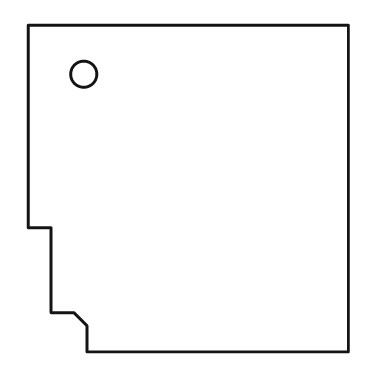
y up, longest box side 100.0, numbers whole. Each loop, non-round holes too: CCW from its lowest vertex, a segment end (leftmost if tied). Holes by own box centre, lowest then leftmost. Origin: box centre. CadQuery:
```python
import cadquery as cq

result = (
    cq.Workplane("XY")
    .moveTo(-31.0, -50.0)
    .lineTo(49.0, -50.0)
    .lineTo(49.0, 50.0)
    .lineTo(-49.0, 50.0)
    .lineTo(-49.0, -12.0)
    .lineTo(-42.0, -12.0)
    .lineTo(-42.0, -38.0)
    .lineTo(-35.0, -38.0)
    .lineTo(-31.0, -42.0)
    .close()
    .moveTo(-32.0, 35.0)
    .circle(4.0)
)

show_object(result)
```